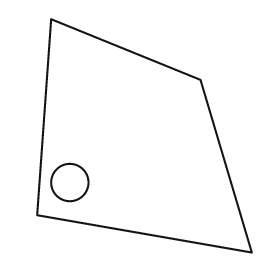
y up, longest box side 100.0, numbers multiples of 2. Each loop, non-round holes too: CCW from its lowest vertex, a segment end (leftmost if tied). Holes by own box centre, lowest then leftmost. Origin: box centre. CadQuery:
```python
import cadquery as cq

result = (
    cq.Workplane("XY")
    .moveTo(46.0, -50.0)
    .lineTo(24.0, 24.0)
    .lineTo(-40.0, 50.0)
    .lineTo(-46.0, -34.0)
    .close()
    .moveTo(-32.0, -20.0)
    .circle(8.0)
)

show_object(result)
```